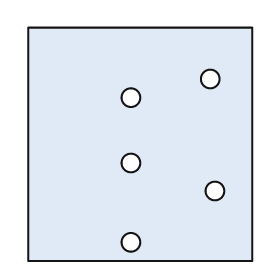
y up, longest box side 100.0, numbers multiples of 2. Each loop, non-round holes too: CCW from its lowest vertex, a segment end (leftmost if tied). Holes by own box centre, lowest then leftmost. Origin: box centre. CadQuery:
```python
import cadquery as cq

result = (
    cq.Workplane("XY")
    .moveTo(-48.0, -50.0)
    .lineTo(48.0, -50.0)
    .lineTo(48.0, 50.0)
    .lineTo(-48.0, 50.0)
    .close()
    .moveTo(-4.0, -42.0)
    .circle(4.0)
    .moveTo(32.0, -20.0)
    .circle(4.0)
    .moveTo(-4.0, -8.0)
    .circle(4.0)
    .moveTo(-4.0, 20.0)
    .circle(4.0)
    .moveTo(30.0, 28.0)
    .circle(4.0)
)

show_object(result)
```